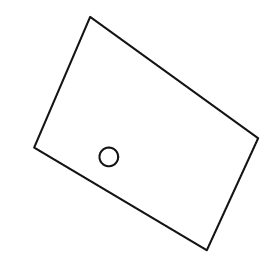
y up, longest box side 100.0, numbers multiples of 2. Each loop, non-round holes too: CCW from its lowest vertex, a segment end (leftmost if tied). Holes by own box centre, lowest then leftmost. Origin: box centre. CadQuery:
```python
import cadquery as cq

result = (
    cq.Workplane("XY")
    .moveTo(26.0, -50.0)
    .lineTo(48.0, -2.0)
    .lineTo(-24.0, 50.0)
    .lineTo(-48.0, -6.0)
    .close()
    .moveTo(-16.0, -10.0)
    .circle(4.0)
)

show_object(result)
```